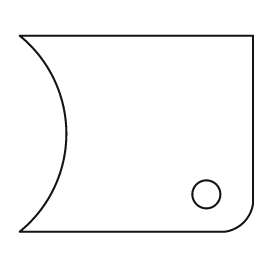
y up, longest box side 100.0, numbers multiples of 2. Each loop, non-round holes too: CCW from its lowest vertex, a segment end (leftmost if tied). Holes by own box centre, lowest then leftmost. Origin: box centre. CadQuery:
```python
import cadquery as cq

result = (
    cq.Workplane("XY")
    .moveTo(-50.0, -42.0)
    .lineTo(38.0, -42.0)
    .threePointArc((46.0, -38.0), (50.0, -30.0))
    .lineTo(50.0, 42.0)
    .lineTo(-50.0, 42.0)
    .threePointArc((-30.0, 0.0), (-50.0, -42.0))
    .close()
    .moveTo(30.0, -26.0)
    .circle(6.0)
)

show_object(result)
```